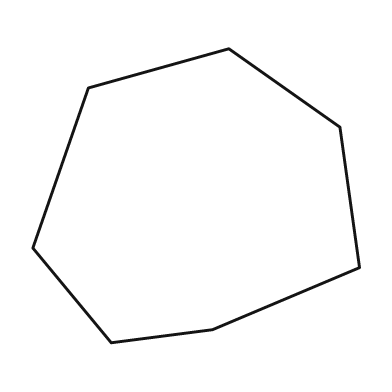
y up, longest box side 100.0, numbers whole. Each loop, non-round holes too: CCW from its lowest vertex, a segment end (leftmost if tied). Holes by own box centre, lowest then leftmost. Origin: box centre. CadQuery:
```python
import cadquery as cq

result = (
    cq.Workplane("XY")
    .moveTo(-26.0, -45.0)
    .lineTo(5.0, -41.0)
    .lineTo(50.0, -22.0)
    .lineTo(44.0, 21.0)
    .lineTo(10.0, 45.0)
    .lineTo(-33.0, 33.0)
    .lineTo(-50.0, -16.0)
    .close()
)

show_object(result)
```